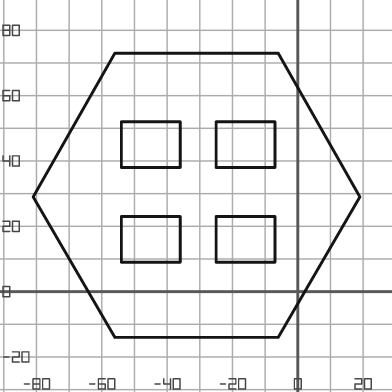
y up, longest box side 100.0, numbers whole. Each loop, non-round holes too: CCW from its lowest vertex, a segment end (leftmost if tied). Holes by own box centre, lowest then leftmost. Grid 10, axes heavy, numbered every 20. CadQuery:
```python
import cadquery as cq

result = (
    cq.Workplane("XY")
    .moveTo(-56.0, -14.0)
    .lineTo(-6.0, -14.0)
    .lineTo(19.0, 29.0)
    .lineTo(-6.0, 73.0)
    .lineTo(-56.0, 73.0)
    .lineTo(-81.0, 29.0)
    .close()
    .moveTo(-54.0, 9.0)
    .lineTo(-36.0, 9.0)
    .lineTo(-36.0, 23.0)
    .lineTo(-54.0, 23.0)
    .close()
    .moveTo(-25.0, 9.0)
    .lineTo(-7.0, 9.0)
    .lineTo(-7.0, 23.0)
    .lineTo(-25.0, 23.0)
    .close()
    .moveTo(-54.0, 38.0)
    .lineTo(-36.0, 38.0)
    .lineTo(-36.0, 52.0)
    .lineTo(-54.0, 52.0)
    .close()
    .moveTo(-25.0, 38.0)
    .lineTo(-7.0, 38.0)
    .lineTo(-7.0, 52.0)
    .lineTo(-25.0, 52.0)
    .close()
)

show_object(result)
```